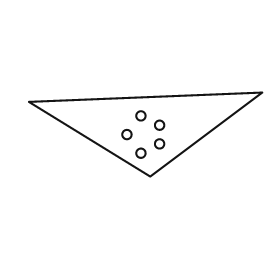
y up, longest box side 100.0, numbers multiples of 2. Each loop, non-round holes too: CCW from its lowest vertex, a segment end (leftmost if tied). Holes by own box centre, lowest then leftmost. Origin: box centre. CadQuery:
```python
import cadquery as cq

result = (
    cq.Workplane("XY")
    .moveTo(2.0, -18.0)
    .lineTo(50.0, 18.0)
    .lineTo(-50.0, 14.0)
    .close()
    .moveTo(-2.0, -8.0)
    .circle(2.0)
    .moveTo(6.0, -4.0)
    .circle(2.0)
    .moveTo(-8.0, 0.0)
    .circle(2.0)
    .moveTo(6.0, 4.0)
    .circle(2.0)
    .moveTo(-2.0, 8.0)
    .circle(2.0)
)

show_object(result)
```